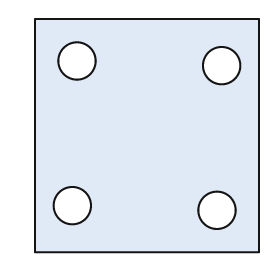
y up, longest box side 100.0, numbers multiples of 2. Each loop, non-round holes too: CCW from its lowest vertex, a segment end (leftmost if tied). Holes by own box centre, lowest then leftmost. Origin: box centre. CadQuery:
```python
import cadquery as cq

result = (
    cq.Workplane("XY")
    .moveTo(-48.0, -50.0)
    .lineTo(48.0, -50.0)
    .lineTo(48.0, 50.0)
    .lineTo(-48.0, 50.0)
    .close()
    .moveTo(30.0, -32.0)
    .circle(8.0)
    .moveTo(-32.0, -30.0)
    .circle(8.0)
    .moveTo(32.0, 30.0)
    .circle(8.0)
    .moveTo(-30.0, 32.0)
    .circle(8.0)
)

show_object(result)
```